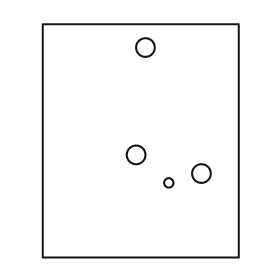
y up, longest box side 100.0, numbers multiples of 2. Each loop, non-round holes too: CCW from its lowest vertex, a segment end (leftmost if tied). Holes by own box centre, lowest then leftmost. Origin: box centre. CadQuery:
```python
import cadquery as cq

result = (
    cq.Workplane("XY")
    .moveTo(-42.0, -50.0)
    .lineTo(42.0, -50.0)
    .lineTo(42.0, 50.0)
    .lineTo(-42.0, 50.0)
    .close()
    .moveTo(12.0, -18.0)
    .circle(2.0)
    .moveTo(26.0, -14.0)
    .circle(4.0)
    .moveTo(-2.0, -6.0)
    .circle(4.0)
    .moveTo(2.0, 40.0)
    .circle(4.0)
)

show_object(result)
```